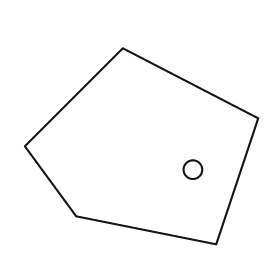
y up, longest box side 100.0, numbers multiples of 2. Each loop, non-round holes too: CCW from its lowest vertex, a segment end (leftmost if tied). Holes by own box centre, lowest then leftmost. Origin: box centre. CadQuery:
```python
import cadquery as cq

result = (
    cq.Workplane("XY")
    .moveTo(32.0, -42.0)
    .lineTo(50.0, 12.0)
    .lineTo(-8.0, 42.0)
    .lineTo(-50.0, 0.0)
    .lineTo(-28.0, -30.0)
    .close()
    .moveTo(22.0, -10.0)
    .circle(4.0)
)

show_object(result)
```